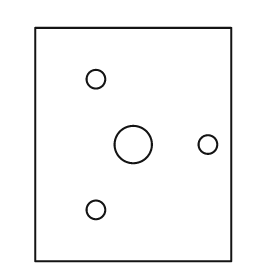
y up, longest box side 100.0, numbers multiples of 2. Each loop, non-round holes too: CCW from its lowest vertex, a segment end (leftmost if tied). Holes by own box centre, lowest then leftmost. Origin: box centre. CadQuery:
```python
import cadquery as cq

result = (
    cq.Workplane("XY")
    .moveTo(-42.0, -50.0)
    .lineTo(42.0, -50.0)
    .lineTo(42.0, 50.0)
    .lineTo(-42.0, 50.0)
    .close()
    .moveTo(-16.0, -28.0)
    .circle(4.0)
    .moveTo(0.0, 0.0)
    .circle(8.0)
    .moveTo(32.0, 0.0)
    .circle(4.0)
    .moveTo(-16.0, 28.0)
    .circle(4.0)
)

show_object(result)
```